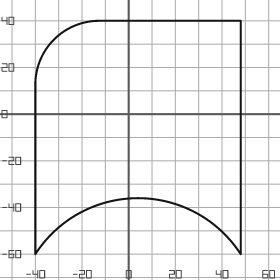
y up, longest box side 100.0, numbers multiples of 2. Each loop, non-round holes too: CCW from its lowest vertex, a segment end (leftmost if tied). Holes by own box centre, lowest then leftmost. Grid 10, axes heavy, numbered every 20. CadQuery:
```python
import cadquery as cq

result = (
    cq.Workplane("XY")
    .moveTo(-40.0, -60.0)
    .threePointArc((4.0, -36.0), (48.0, -60.0))
    .lineTo(48.0, 40.0)
    .lineTo(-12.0, 40.0)
    .threePointArc((-32.0, 32.0), (-40.0, 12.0))
    .close()
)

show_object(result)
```